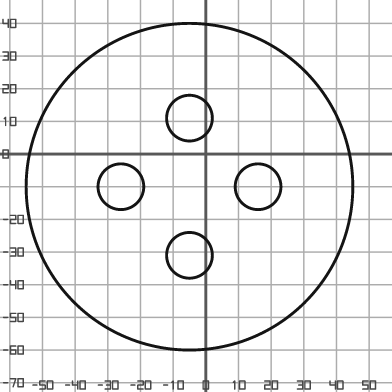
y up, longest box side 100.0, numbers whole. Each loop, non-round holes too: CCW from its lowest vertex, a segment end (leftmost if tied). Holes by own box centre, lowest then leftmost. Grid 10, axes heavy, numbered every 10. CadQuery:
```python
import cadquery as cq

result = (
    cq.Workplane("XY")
    .moveTo(-5.0, -10.0)
    .circle(50.0)
    .moveTo(-5.0, -31.0)
    .circle(7.0)
    .moveTo(-26.0, -10.0)
    .circle(7.0)
    .moveTo(16.0, -10.0)
    .circle(7.0)
    .moveTo(-5.0, 11.0)
    .circle(7.0)
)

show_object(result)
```